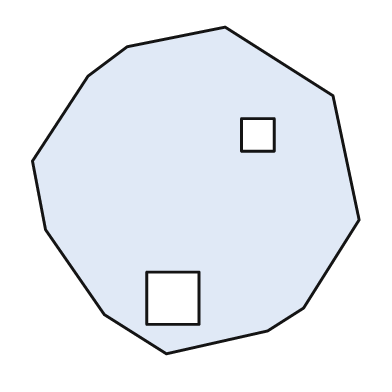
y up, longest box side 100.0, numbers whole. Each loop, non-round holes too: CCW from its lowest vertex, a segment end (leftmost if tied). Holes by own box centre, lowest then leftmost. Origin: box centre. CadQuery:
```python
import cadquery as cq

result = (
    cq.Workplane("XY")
    .moveTo(-9.0, -50.0)
    .lineTo(22.0, -43.0)
    .lineTo(33.0, -36.0)
    .lineTo(50.0, -9.0)
    .lineTo(42.0, 29.0)
    .lineTo(9.0, 50.0)
    .lineTo(-21.0, 44.0)
    .lineTo(-33.0, 35.0)
    .lineTo(-50.0, 9.0)
    .lineTo(-46.0, -12.0)
    .lineTo(-28.0, -38.0)
    .close()
    .moveTo(-15.0, -41.0)
    .lineTo(1.0, -41.0)
    .lineTo(1.0, -25.0)
    .lineTo(-15.0, -25.0)
    .close()
    .moveTo(14.0, 12.0)
    .lineTo(24.0, 12.0)
    .lineTo(24.0, 22.0)
    .lineTo(14.0, 22.0)
    .close()
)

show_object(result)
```